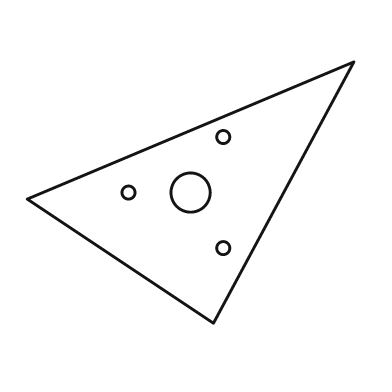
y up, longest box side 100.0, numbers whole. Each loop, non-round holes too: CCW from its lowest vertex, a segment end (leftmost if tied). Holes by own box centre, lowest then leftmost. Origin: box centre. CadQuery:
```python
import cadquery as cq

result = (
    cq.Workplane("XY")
    .moveTo(7.0, -40.0)
    .lineTo(50.0, 40.0)
    .lineTo(-50.0, -2.0)
    .close()
    .moveTo(10.0, -17.0)
    .circle(2.0)
    .moveTo(-19.0, 0.0)
    .circle(2.0)
    .moveTo(0.0, 0.0)
    .circle(6.0)
    .moveTo(10.0, 17.0)
    .circle(2.0)
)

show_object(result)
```